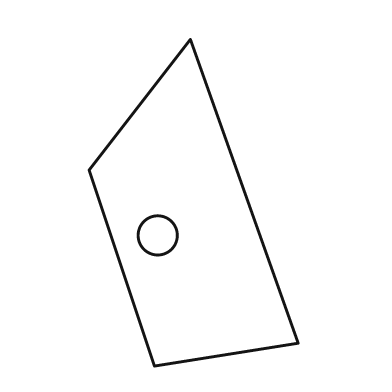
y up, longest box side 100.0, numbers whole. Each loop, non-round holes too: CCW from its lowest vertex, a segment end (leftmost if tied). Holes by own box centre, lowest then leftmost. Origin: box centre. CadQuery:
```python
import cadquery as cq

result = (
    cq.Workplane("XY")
    .moveTo(-12.0, -50.0)
    .lineTo(32.0, -43.0)
    .lineTo(-1.0, 50.0)
    .lineTo(-32.0, 10.0)
    .close()
    .moveTo(-11.0, -10.0)
    .circle(6.0)
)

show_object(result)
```